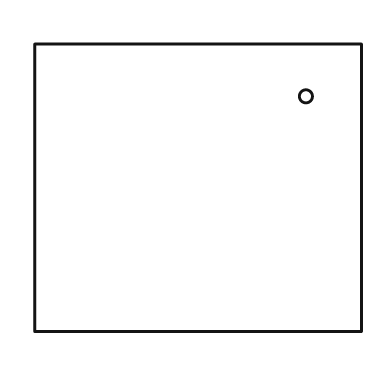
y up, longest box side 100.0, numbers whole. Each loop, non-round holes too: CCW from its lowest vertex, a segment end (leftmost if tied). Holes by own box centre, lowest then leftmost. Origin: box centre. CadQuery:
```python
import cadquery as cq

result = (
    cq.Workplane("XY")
    .moveTo(-50.0, -44.0)
    .lineTo(50.0, -44.0)
    .lineTo(50.0, 44.0)
    .lineTo(-50.0, 44.0)
    .close()
    .moveTo(33.0, 28.0)
    .circle(2.0)
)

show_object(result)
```